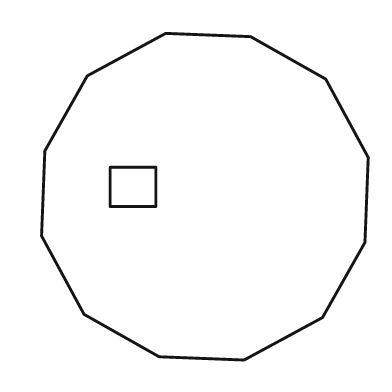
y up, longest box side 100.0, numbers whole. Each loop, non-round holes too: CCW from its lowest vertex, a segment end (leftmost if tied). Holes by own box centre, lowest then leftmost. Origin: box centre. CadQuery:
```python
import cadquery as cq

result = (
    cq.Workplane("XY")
    .moveTo(12.0, -50.0)
    .lineTo(36.0, -37.0)
    .lineTo(49.0, -14.0)
    .lineTo(50.0, 12.0)
    .lineTo(37.0, 36.0)
    .lineTo(14.0, 49.0)
    .lineTo(-12.0, 50.0)
    .lineTo(-36.0, 37.0)
    .lineTo(-49.0, 14.0)
    .lineTo(-50.0, -12.0)
    .lineTo(-37.0, -36.0)
    .lineTo(-14.0, -49.0)
    .close()
    .moveTo(-29.0, -3.0)
    .lineTo(-15.0, -3.0)
    .lineTo(-15.0, 9.0)
    .lineTo(-29.0, 9.0)
    .close()
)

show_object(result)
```